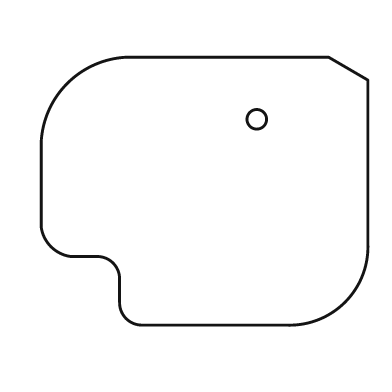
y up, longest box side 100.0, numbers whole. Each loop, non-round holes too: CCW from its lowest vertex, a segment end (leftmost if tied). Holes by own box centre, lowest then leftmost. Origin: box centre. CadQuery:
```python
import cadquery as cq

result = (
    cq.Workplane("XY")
    .moveTo(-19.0, -41.0)
    .lineTo(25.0, -41.0)
    .threePointArc((43.0, -34.0), (50.0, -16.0))
    .lineTo(50.0, 34.0)
    .lineTo(38.0, 41.0)
    .lineTo(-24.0, 41.0)
    .threePointArc((-42.0, 33.0), (-50.0, 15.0))
    .lineTo(-50.0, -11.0)
    .threePointArc((-47.0, -17.0), (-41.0, -20.0))
    .lineTo(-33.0, -20.0)
    .threePointArc((-28.0, -22.0), (-26.0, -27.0))
    .lineTo(-26.0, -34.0)
    .threePointArc((-24.0, -39.0), (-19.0, -41.0))
    .close()
    .moveTo(16.0, 22.0)
    .circle(3.0)
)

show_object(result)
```